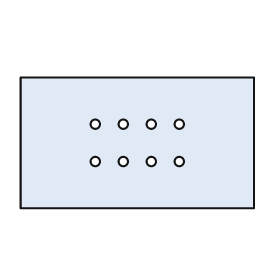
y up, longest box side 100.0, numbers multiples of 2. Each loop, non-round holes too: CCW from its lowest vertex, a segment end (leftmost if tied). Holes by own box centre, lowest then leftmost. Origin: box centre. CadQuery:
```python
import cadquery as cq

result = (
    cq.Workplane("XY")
    .moveTo(-50.0, -28.0)
    .lineTo(50.0, -28.0)
    .lineTo(50.0, 28.0)
    .lineTo(-50.0, 28.0)
    .close()
    .moveTo(-18.0, -8.0)
    .circle(2.0)
    .moveTo(-6.0, -8.0)
    .circle(2.0)
    .moveTo(6.0, -8.0)
    .circle(2.0)
    .moveTo(18.0, -8.0)
    .circle(2.0)
    .moveTo(-18.0, 8.0)
    .circle(2.0)
    .moveTo(-6.0, 8.0)
    .circle(2.0)
    .moveTo(6.0, 8.0)
    .circle(2.0)
    .moveTo(18.0, 8.0)
    .circle(2.0)
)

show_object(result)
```